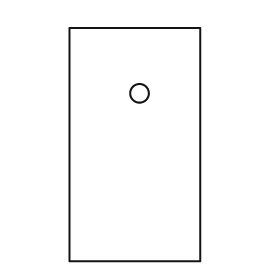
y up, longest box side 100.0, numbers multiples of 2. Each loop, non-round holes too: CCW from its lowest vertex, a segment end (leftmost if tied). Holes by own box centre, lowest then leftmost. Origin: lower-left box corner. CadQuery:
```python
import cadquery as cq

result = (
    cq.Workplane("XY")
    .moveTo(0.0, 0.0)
    .lineTo(56.0, 0.0)
    .lineTo(56.0, 100.0)
    .lineTo(0.0, 100.0)
    .close()
    .moveTo(30.0, 72.0)
    .circle(4.0)
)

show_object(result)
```